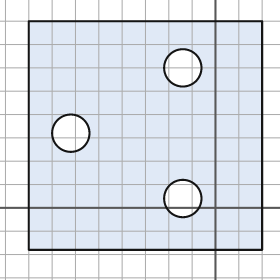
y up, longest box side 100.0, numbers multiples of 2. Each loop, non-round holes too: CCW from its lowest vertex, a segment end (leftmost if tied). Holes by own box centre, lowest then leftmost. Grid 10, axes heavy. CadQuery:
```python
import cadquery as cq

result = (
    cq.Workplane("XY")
    .moveTo(-80.0, -18.0)
    .lineTo(20.0, -18.0)
    .lineTo(20.0, 80.0)
    .lineTo(-80.0, 80.0)
    .close()
    .moveTo(-14.0, 4.0)
    .circle(8.0)
    .moveTo(-62.0, 32.0)
    .circle(8.0)
    .moveTo(-14.0, 60.0)
    .circle(8.0)
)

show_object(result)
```